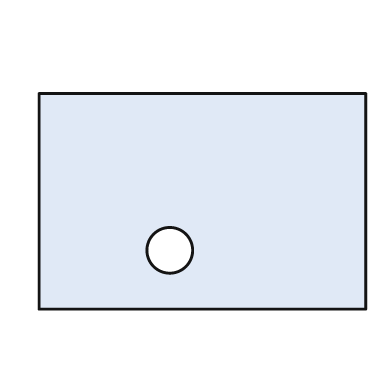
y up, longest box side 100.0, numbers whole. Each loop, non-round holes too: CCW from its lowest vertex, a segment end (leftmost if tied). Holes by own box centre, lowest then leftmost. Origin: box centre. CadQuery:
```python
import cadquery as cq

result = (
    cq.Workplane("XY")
    .moveTo(-50.0, -33.0)
    .lineTo(50.0, -33.0)
    .lineTo(50.0, 33.0)
    .lineTo(-50.0, 33.0)
    .close()
    .moveTo(-10.0, -15.0)
    .circle(7.0)
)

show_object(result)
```